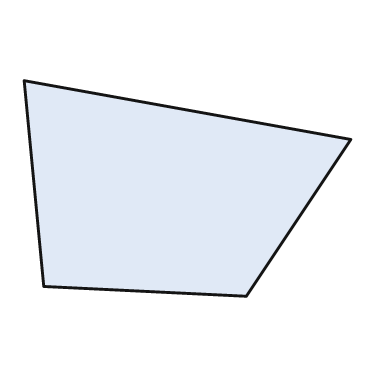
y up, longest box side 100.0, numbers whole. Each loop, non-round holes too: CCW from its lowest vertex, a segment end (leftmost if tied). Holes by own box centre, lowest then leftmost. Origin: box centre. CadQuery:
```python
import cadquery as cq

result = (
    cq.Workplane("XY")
    .moveTo(18.0, -33.0)
    .lineTo(50.0, 15.0)
    .lineTo(-50.0, 33.0)
    .lineTo(-44.0, -30.0)
    .close()
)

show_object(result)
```